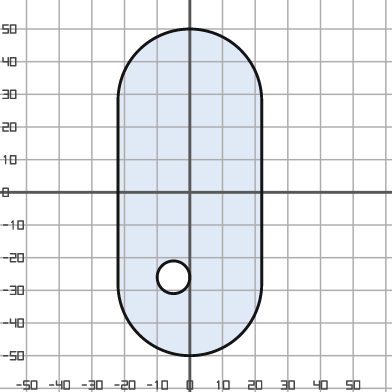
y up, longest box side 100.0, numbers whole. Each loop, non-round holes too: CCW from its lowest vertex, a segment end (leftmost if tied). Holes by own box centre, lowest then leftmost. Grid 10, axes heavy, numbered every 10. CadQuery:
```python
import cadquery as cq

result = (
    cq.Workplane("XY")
    .moveTo(-22.0, -28.0)
    .threePointArc((0.0, -50.0), (22.0, -28.0))
    .lineTo(22.0, 28.0)
    .threePointArc((0.0, 50.0), (-22.0, 28.0))
    .close()
    .moveTo(-5.0, -26.0)
    .circle(5.0)
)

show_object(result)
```